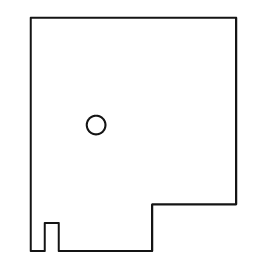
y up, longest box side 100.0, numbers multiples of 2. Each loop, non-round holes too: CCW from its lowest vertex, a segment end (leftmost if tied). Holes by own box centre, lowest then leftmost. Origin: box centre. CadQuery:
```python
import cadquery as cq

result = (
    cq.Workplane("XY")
    .moveTo(-44.0, -50.0)
    .lineTo(-38.0, -50.0)
    .lineTo(-38.0, -38.0)
    .lineTo(-32.0, -38.0)
    .lineTo(-32.0, -50.0)
    .lineTo(8.0, -50.0)
    .lineTo(8.0, -30.0)
    .lineTo(44.0, -30.0)
    .lineTo(44.0, 50.0)
    .lineTo(-44.0, 50.0)
    .close()
    .moveTo(-16.0, 4.0)
    .circle(4.0)
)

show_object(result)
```